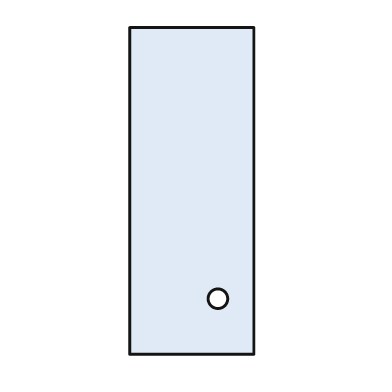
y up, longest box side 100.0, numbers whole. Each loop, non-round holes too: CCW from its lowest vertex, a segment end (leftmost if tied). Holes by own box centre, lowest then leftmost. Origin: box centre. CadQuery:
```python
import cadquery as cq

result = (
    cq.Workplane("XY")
    .moveTo(-19.0, -50.0)
    .lineTo(19.0, -50.0)
    .lineTo(19.0, 50.0)
    .lineTo(-19.0, 50.0)
    .close()
    .moveTo(8.0, -33.0)
    .circle(3.0)
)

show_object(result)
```